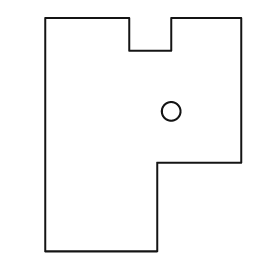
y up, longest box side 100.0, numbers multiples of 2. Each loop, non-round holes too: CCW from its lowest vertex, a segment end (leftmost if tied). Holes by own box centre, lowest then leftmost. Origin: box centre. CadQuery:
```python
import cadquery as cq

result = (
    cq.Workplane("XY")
    .moveTo(-42.0, -50.0)
    .lineTo(6.0, -50.0)
    .lineTo(6.0, -12.0)
    .lineTo(42.0, -12.0)
    .lineTo(42.0, 50.0)
    .lineTo(12.0, 50.0)
    .lineTo(12.0, 36.0)
    .lineTo(-6.0, 36.0)
    .lineTo(-6.0, 50.0)
    .lineTo(-42.0, 50.0)
    .close()
    .moveTo(12.0, 10.0)
    .circle(4.0)
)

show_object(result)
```